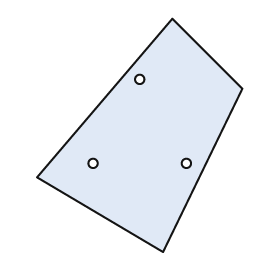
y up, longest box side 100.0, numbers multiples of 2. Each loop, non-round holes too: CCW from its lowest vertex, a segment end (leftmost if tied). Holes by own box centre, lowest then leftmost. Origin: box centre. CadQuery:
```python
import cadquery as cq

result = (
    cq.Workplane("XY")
    .moveTo(10.0, -50.0)
    .lineTo(44.0, 20.0)
    .lineTo(14.0, 50.0)
    .lineTo(-44.0, -18.0)
    .close()
    .moveTo(-20.0, -12.0)
    .circle(2.0)
    .moveTo(20.0, -12.0)
    .circle(2.0)
    .moveTo(0.0, 24.0)
    .circle(2.0)
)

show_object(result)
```